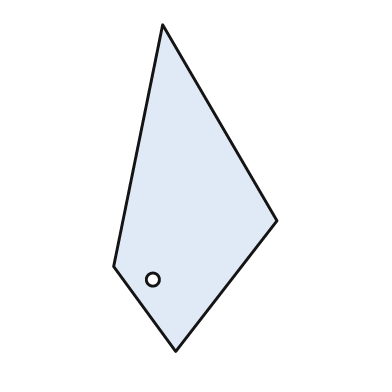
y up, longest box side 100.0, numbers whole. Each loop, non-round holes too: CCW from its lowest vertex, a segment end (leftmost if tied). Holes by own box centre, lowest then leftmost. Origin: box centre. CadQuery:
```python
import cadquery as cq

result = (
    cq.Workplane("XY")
    .moveTo(-6.0, -50.0)
    .lineTo(25.0, -10.0)
    .lineTo(-10.0, 50.0)
    .lineTo(-25.0, -24.0)
    .close()
    .moveTo(-13.0, -28.0)
    .circle(2.0)
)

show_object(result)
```